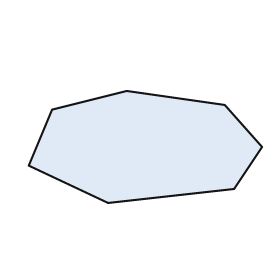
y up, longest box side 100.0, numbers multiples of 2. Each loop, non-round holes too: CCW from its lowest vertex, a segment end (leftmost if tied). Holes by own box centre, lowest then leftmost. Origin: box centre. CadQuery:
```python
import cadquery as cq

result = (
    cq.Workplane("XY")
    .moveTo(-16.0, -24.0)
    .lineTo(38.0, -18.0)
    .lineTo(50.0, 0.0)
    .lineTo(34.0, 18.0)
    .lineTo(-8.0, 24.0)
    .lineTo(-40.0, 16.0)
    .lineTo(-50.0, -8.0)
    .close()
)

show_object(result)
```